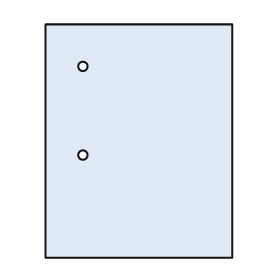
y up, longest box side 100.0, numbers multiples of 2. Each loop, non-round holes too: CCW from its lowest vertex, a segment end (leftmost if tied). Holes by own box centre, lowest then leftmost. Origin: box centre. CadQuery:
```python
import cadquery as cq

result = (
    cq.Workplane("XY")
    .moveTo(-40.0, -50.0)
    .lineTo(40.0, -50.0)
    .lineTo(40.0, 50.0)
    .lineTo(-40.0, 50.0)
    .close()
    .moveTo(-24.0, -6.0)
    .circle(2.0)
    .moveTo(-24.0, 32.0)
    .circle(2.0)
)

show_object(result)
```